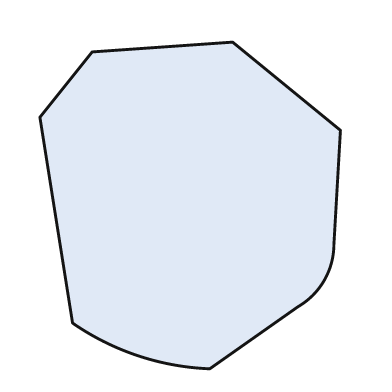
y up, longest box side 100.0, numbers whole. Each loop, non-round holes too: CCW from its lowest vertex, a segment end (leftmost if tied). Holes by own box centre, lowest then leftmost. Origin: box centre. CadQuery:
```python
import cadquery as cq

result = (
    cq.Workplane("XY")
    .moveTo(6.0, -50.0)
    .lineTo(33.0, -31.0)
    .threePointArc((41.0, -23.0), (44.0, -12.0))
    .lineTo(46.0, 23.0)
    .lineTo(13.0, 50.0)
    .lineTo(-30.0, 47.0)
    .lineTo(-46.0, 27.0)
    .lineTo(-36.0, -36.0)
    .threePointArc((-16.0, -46.0), (6.0, -50.0))
    .close()
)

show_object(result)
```